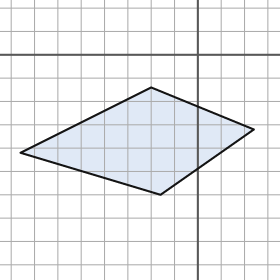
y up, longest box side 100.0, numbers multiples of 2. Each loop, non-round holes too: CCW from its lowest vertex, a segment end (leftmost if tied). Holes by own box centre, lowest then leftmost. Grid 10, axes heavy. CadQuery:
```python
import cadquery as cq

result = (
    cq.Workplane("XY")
    .moveTo(-16.0, -60.0)
    .lineTo(24.0, -32.0)
    .lineTo(-20.0, -14.0)
    .lineTo(-76.0, -42.0)
    .close()
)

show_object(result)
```